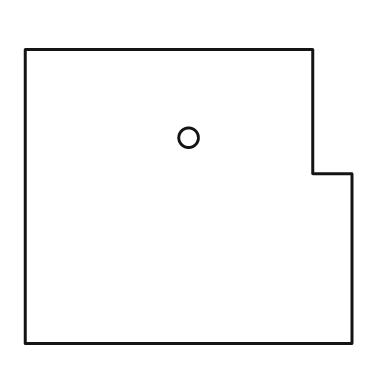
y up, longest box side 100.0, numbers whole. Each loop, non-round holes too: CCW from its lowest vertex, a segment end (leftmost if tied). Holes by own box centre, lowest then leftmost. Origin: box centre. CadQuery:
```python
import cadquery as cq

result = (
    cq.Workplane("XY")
    .moveTo(-50.0, -45.0)
    .lineTo(50.0, -45.0)
    .lineTo(50.0, 7.0)
    .lineTo(38.0, 7.0)
    .lineTo(38.0, 45.0)
    .lineTo(-50.0, 45.0)
    .close()
    .moveTo(0.0, 18.0)
    .circle(3.0)
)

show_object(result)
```